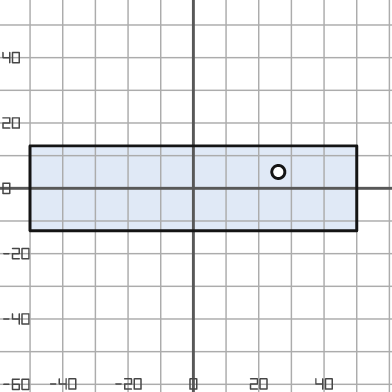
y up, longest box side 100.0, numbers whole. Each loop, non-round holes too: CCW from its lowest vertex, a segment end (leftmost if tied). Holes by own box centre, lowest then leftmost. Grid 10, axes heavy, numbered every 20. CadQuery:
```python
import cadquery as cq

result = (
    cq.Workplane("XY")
    .moveTo(-50.0, -13.0)
    .lineTo(50.0, -13.0)
    .lineTo(50.0, 13.0)
    .lineTo(-50.0, 13.0)
    .close()
    .moveTo(26.0, 5.0)
    .circle(2.0)
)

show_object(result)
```